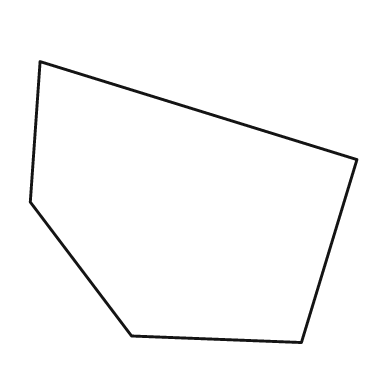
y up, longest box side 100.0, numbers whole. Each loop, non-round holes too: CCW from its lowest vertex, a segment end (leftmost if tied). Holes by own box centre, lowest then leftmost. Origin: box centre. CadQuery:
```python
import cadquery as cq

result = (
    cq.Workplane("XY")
    .moveTo(33.0, -43.0)
    .lineTo(50.0, 13.0)
    .lineTo(-47.0, 43.0)
    .lineTo(-50.0, 0.0)
    .lineTo(-19.0, -41.0)
    .close()
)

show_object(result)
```